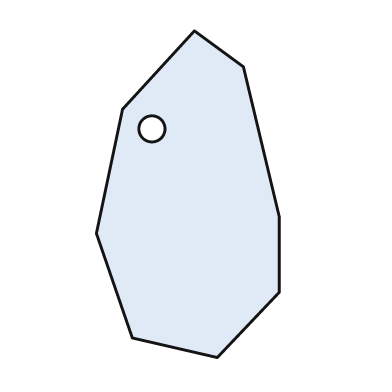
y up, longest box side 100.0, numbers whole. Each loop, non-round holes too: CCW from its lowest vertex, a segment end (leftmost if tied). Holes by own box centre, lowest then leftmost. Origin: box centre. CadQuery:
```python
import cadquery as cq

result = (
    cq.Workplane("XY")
    .moveTo(9.0, -50.0)
    .lineTo(28.0, -30.0)
    .lineTo(28.0, -7.0)
    .lineTo(17.0, 39.0)
    .lineTo(2.0, 50.0)
    .lineTo(-20.0, 26.0)
    .lineTo(-28.0, -12.0)
    .lineTo(-17.0, -44.0)
    .close()
    .moveTo(-11.0, 20.0)
    .circle(4.0)
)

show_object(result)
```